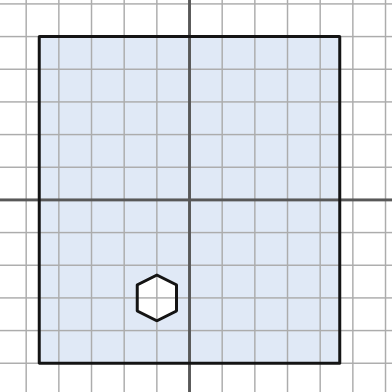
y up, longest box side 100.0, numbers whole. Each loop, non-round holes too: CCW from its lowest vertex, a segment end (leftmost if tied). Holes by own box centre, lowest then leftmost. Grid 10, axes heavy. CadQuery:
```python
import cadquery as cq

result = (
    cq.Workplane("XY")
    .moveTo(-46.0, -50.0)
    .lineTo(46.0, -50.0)
    .lineTo(46.0, 50.0)
    .lineTo(-46.0, 50.0)
    .close()
    .moveTo(-10.0, -37.0)
    .lineTo(-4.0, -34.0)
    .lineTo(-4.0, -26.0)
    .lineTo(-10.0, -23.0)
    .lineTo(-16.0, -26.0)
    .lineTo(-16.0, -34.0)
    .close()
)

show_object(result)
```